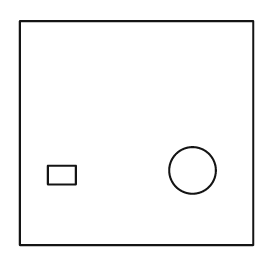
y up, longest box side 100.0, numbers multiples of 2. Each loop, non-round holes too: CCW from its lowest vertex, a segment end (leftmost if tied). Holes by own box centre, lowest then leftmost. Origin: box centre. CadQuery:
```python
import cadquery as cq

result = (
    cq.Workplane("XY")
    .moveTo(-50.0, -48.0)
    .lineTo(50.0, -48.0)
    .lineTo(50.0, 48.0)
    .lineTo(-50.0, 48.0)
    .close()
    .moveTo(-38.0, -22.0)
    .lineTo(-26.0, -22.0)
    .lineTo(-26.0, -14.0)
    .lineTo(-38.0, -14.0)
    .close()
    .moveTo(24.0, -16.0)
    .circle(10.0)
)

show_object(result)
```